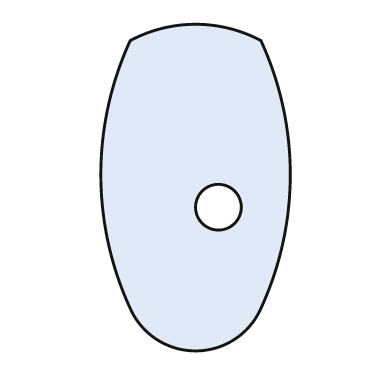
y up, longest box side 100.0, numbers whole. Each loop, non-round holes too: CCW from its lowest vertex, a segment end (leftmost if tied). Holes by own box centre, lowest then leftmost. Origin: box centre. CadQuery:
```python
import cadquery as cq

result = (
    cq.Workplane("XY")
    .moveTo(-20.0, -37.0)
    .threePointArc((0.0, -50.0), (20.0, -37.0))
    .threePointArc((29.0, 4.0), (20.0, 45.0))
    .threePointArc((0.0, 50.0), (-20.0, 45.0))
    .threePointArc((-29.0, 4.0), (-20.0, -37.0))
    .close()
    .moveTo(7.0, -6.0)
    .circle(7.0)
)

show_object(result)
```